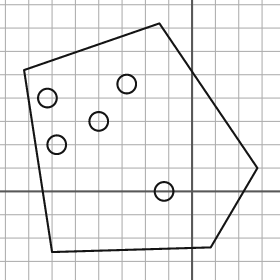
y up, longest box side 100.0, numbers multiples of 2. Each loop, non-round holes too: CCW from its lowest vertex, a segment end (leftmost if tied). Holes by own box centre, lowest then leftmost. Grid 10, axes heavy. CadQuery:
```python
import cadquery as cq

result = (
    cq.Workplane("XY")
    .moveTo(-60.0, -26.0)
    .lineTo(8.0, -24.0)
    .lineTo(28.0, 10.0)
    .lineTo(-14.0, 72.0)
    .lineTo(-72.0, 52.0)
    .close()
    .moveTo(-12.0, 0.0)
    .circle(4.0)
    .moveTo(-58.0, 20.0)
    .circle(4.0)
    .moveTo(-40.0, 30.0)
    .circle(4.0)
    .moveTo(-62.0, 40.0)
    .circle(4.0)
    .moveTo(-28.0, 46.0)
    .circle(4.0)
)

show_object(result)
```